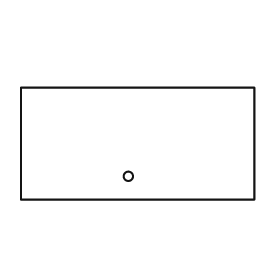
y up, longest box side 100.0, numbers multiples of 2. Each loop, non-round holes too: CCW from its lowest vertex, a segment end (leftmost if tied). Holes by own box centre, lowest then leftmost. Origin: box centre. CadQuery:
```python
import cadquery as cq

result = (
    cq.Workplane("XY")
    .moveTo(-50.0, -24.0)
    .lineTo(50.0, -24.0)
    .lineTo(50.0, 24.0)
    .lineTo(-50.0, 24.0)
    .close()
    .moveTo(-4.0, -14.0)
    .circle(2.0)
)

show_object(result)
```